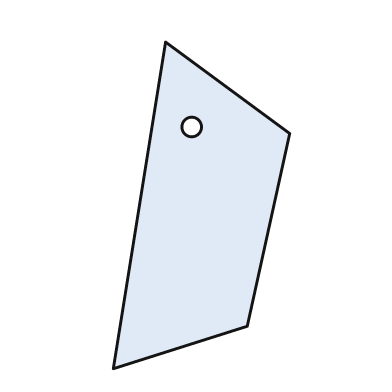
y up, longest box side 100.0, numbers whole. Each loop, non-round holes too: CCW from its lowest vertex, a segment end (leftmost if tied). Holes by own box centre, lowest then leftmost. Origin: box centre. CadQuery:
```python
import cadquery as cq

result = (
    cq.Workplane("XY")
    .moveTo(-27.0, -50.0)
    .lineTo(14.0, -37.0)
    .lineTo(27.0, 22.0)
    .lineTo(-11.0, 50.0)
    .close()
    .moveTo(-3.0, 24.0)
    .circle(3.0)
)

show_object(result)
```